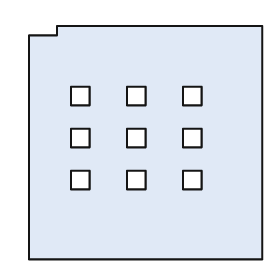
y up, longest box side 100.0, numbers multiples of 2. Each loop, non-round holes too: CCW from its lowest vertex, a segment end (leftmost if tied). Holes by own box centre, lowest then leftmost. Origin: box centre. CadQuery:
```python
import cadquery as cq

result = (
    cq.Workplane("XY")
    .moveTo(-50.0, -50.0)
    .lineTo(50.0, -50.0)
    .lineTo(50.0, 50.0)
    .lineTo(-38.0, 50.0)
    .lineTo(-38.0, 46.0)
    .lineTo(-50.0, 46.0)
    .close()
    .moveTo(-32.0, -20.0)
    .lineTo(-24.0, -20.0)
    .lineTo(-24.0, -12.0)
    .lineTo(-32.0, -12.0)
    .close()
    .moveTo(-8.0, -20.0)
    .lineTo(0.0, -20.0)
    .lineTo(0.0, -12.0)
    .lineTo(-8.0, -12.0)
    .close()
    .moveTo(16.0, -20.0)
    .lineTo(24.0, -20.0)
    .lineTo(24.0, -12.0)
    .lineTo(16.0, -12.0)
    .close()
    .moveTo(-32.0, -2.0)
    .lineTo(-24.0, -2.0)
    .lineTo(-24.0, 6.0)
    .lineTo(-32.0, 6.0)
    .close()
    .moveTo(-8.0, -2.0)
    .lineTo(0.0, -2.0)
    .lineTo(0.0, 6.0)
    .lineTo(-8.0, 6.0)
    .close()
    .moveTo(16.0, -2.0)
    .lineTo(24.0, -2.0)
    .lineTo(24.0, 6.0)
    .lineTo(16.0, 6.0)
    .close()
    .moveTo(-32.0, 16.0)
    .lineTo(-24.0, 16.0)
    .lineTo(-24.0, 24.0)
    .lineTo(-32.0, 24.0)
    .close()
    .moveTo(-8.0, 16.0)
    .lineTo(0.0, 16.0)
    .lineTo(0.0, 24.0)
    .lineTo(-8.0, 24.0)
    .close()
    .moveTo(16.0, 16.0)
    .lineTo(24.0, 16.0)
    .lineTo(24.0, 24.0)
    .lineTo(16.0, 24.0)
    .close()
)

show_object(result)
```